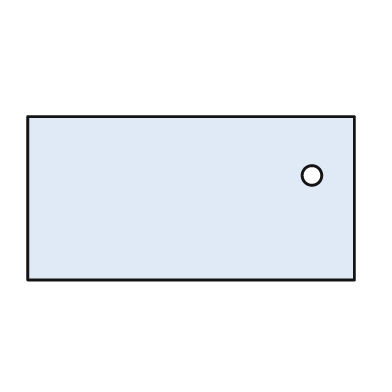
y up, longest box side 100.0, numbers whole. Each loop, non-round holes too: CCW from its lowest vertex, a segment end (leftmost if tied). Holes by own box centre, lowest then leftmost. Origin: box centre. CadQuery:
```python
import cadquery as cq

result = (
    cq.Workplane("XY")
    .moveTo(-50.0, -25.0)
    .lineTo(50.0, -25.0)
    .lineTo(50.0, 25.0)
    .lineTo(-50.0, 25.0)
    .close()
    .moveTo(37.0, 7.0)
    .circle(3.0)
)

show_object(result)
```